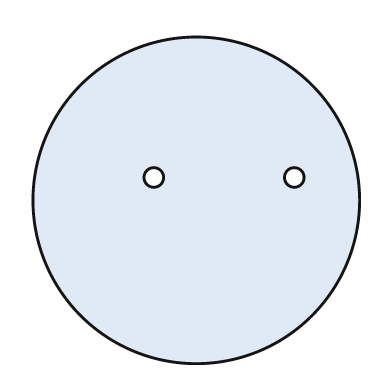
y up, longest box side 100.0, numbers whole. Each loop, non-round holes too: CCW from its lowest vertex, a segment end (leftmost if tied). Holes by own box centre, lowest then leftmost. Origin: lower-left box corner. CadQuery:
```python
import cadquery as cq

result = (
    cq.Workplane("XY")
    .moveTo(50.0, 50.0)
    .circle(50.0)
    .moveTo(37.0, 57.0)
    .circle(3.0)
    .moveTo(80.0, 57.0)
    .circle(3.0)
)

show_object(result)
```